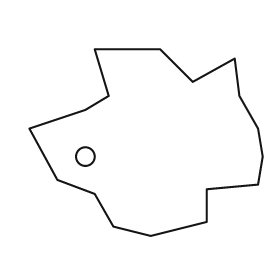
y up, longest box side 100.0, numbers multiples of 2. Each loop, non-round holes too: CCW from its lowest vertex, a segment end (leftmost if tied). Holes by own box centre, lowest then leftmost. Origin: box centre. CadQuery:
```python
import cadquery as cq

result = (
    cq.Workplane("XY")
    .moveTo(2.0, -40.0)
    .lineTo(26.0, -34.0)
    .lineTo(26.0, -20.0)
    .lineTo(48.0, -18.0)
    .lineTo(50.0, -6.0)
    .lineTo(48.0, 6.0)
    .lineTo(40.0, 20.0)
    .lineTo(38.0, 36.0)
    .lineTo(20.0, 26.0)
    .lineTo(6.0, 40.0)
    .lineTo(-22.0, 40.0)
    .lineTo(-16.0, 20.0)
    .lineTo(-26.0, 14.0)
    .lineTo(-50.0, 6.0)
    .lineTo(-38.0, -16.0)
    .lineTo(-22.0, -22.0)
    .lineTo(-14.0, -36.0)
    .close()
    .moveTo(-26.0, -6.0)
    .circle(4.0)
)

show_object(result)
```